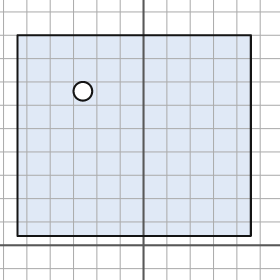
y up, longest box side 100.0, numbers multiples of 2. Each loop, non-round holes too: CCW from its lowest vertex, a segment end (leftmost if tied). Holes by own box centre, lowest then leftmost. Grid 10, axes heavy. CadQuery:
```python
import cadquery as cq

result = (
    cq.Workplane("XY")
    .moveTo(-54.0, 4.0)
    .lineTo(46.0, 4.0)
    .lineTo(46.0, 90.0)
    .lineTo(-54.0, 90.0)
    .close()
    .moveTo(-26.0, 66.0)
    .circle(4.0)
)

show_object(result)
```